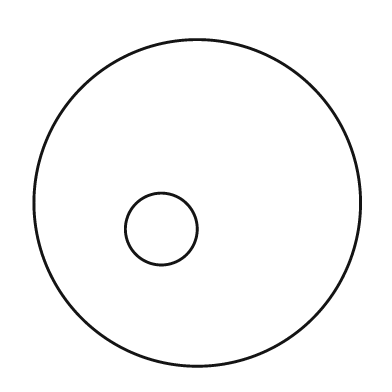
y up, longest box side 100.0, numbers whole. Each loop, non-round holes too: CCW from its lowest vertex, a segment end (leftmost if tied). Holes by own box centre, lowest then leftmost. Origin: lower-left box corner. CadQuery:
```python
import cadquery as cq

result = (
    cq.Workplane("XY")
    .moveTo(50.0, 50.0)
    .circle(50.0)
    .moveTo(39.0, 42.0)
    .circle(11.0)
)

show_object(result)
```